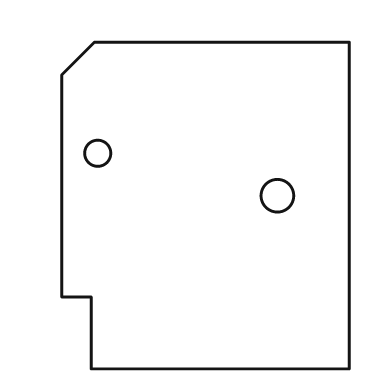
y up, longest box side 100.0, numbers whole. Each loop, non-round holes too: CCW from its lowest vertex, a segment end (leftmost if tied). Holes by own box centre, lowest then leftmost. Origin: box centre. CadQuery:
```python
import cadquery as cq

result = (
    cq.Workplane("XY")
    .moveTo(-35.0, -50.0)
    .lineTo(44.0, -50.0)
    .lineTo(44.0, 50.0)
    .lineTo(-34.0, 50.0)
    .lineTo(-44.0, 40.0)
    .lineTo(-44.0, -28.0)
    .lineTo(-35.0, -28.0)
    .close()
    .moveTo(22.0, 3.0)
    .circle(5.0)
    .moveTo(-33.0, 16.0)
    .circle(4.0)
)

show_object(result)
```